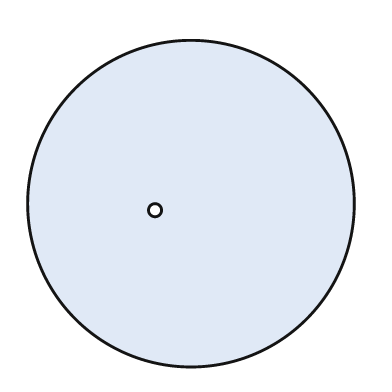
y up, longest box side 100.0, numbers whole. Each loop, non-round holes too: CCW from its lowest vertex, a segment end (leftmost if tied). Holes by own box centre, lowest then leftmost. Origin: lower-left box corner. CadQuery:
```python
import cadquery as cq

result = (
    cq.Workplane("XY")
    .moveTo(50.0, 50.0)
    .circle(50.0)
    .moveTo(39.0, 48.0)
    .circle(2.0)
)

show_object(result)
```